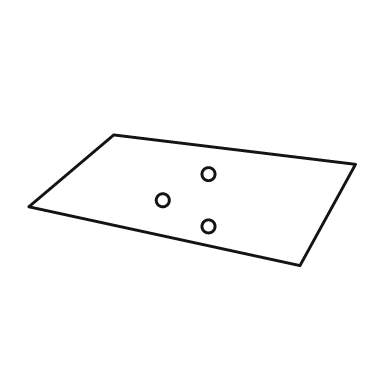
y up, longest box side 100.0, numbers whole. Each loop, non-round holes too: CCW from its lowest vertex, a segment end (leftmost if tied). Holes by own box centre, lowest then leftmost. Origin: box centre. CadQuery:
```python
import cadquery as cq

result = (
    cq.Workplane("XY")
    .moveTo(33.0, -20.0)
    .lineTo(50.0, 11.0)
    .lineTo(-24.0, 20.0)
    .lineTo(-50.0, -2.0)
    .close()
    .moveTo(5.0, -8.0)
    .circle(2.0)
    .moveTo(-9.0, 0.0)
    .circle(2.0)
    .moveTo(5.0, 8.0)
    .circle(2.0)
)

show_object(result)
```